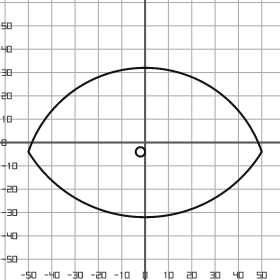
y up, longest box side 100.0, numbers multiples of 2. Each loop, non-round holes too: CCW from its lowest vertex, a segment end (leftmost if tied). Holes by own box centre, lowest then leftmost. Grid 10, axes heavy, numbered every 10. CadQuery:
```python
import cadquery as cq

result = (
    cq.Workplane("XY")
    .moveTo(-50.0, -4.0)
    .threePointArc((0.0, -32.0), (50.0, -4.0))
    .threePointArc((0.0, 32.0), (-50.0, -4.0))
    .close()
    .moveTo(-2.0, -4.0)
    .circle(2.0)
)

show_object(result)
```